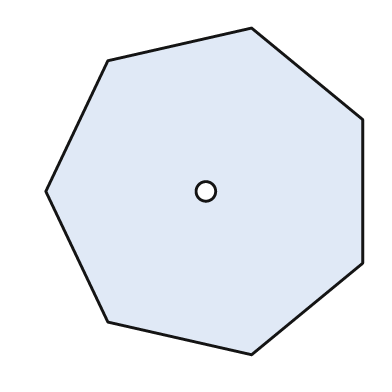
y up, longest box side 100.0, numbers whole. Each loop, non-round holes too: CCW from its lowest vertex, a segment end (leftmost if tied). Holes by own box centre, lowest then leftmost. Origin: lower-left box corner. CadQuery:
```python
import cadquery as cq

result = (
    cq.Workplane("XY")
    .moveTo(63.0, 0.0)
    .lineTo(97.0, 28.0)
    .lineTo(97.0, 72.0)
    .lineTo(63.0, 100.0)
    .lineTo(19.0, 90.0)
    .lineTo(0.0, 50.0)
    .lineTo(19.0, 10.0)
    .close()
    .moveTo(49.0, 50.0)
    .circle(3.0)
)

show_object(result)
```